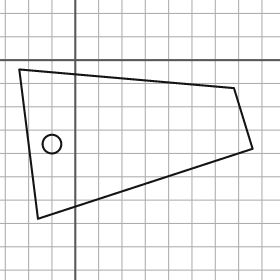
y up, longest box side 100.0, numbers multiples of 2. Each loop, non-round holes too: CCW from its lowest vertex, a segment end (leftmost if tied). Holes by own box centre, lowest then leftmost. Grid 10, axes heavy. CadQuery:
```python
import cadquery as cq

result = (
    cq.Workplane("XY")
    .moveTo(-16.0, -68.0)
    .lineTo(76.0, -38.0)
    .lineTo(68.0, -12.0)
    .lineTo(-24.0, -4.0)
    .close()
    .moveTo(-10.0, -36.0)
    .circle(4.0)
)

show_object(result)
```